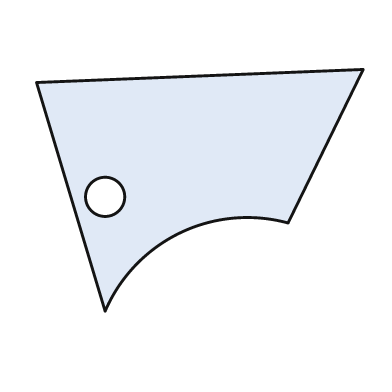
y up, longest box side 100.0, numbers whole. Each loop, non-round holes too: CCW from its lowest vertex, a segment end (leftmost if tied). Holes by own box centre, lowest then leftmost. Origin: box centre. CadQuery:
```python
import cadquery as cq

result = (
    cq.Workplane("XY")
    .moveTo(-29.0, -37.0)
    .threePointArc((-6.0, -13.0), (27.0, -10.0))
    .lineTo(50.0, 37.0)
    .lineTo(-50.0, 33.0)
    .close()
    .moveTo(-29.0, -2.0)
    .circle(6.0)
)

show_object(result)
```